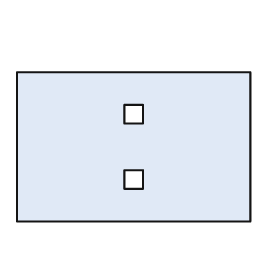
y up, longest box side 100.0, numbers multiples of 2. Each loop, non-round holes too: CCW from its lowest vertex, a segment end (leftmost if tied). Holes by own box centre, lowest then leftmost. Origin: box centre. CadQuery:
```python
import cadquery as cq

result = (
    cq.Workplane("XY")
    .moveTo(-50.0, -32.0)
    .lineTo(50.0, -32.0)
    .lineTo(50.0, 32.0)
    .lineTo(-50.0, 32.0)
    .close()
    .moveTo(-4.0, -18.0)
    .lineTo(4.0, -18.0)
    .lineTo(4.0, -10.0)
    .lineTo(-4.0, -10.0)
    .close()
    .moveTo(-4.0, 10.0)
    .lineTo(4.0, 10.0)
    .lineTo(4.0, 18.0)
    .lineTo(-4.0, 18.0)
    .close()
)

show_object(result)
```